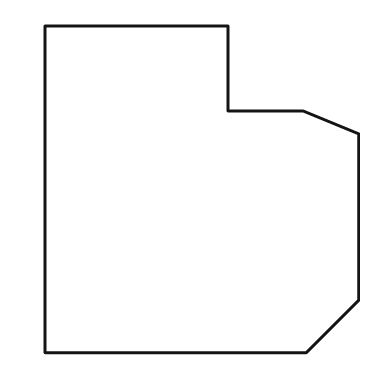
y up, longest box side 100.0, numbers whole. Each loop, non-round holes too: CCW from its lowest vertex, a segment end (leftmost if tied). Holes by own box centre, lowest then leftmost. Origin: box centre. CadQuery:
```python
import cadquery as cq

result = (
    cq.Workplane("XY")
    .moveTo(-48.0, -50.0)
    .lineTo(32.0, -50.0)
    .lineTo(48.0, -34.0)
    .lineTo(48.0, 17.0)
    .lineTo(31.0, 24.0)
    .lineTo(8.0, 24.0)
    .lineTo(8.0, 50.0)
    .lineTo(-48.0, 50.0)
    .close()
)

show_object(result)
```